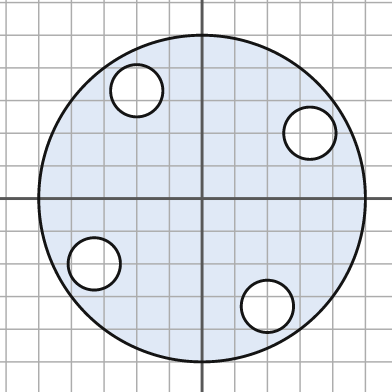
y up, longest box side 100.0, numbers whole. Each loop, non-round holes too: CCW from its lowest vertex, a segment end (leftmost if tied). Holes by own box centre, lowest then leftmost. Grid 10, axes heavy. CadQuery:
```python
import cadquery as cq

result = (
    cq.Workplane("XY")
    .moveTo(0.0, 0.0)
    .circle(50.0)
    .moveTo(20.0, -33.0)
    .circle(8.0)
    .moveTo(-33.0, -20.0)
    .circle(8.0)
    .moveTo(33.0, 20.0)
    .circle(8.0)
    .moveTo(-20.0, 33.0)
    .circle(8.0)
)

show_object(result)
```